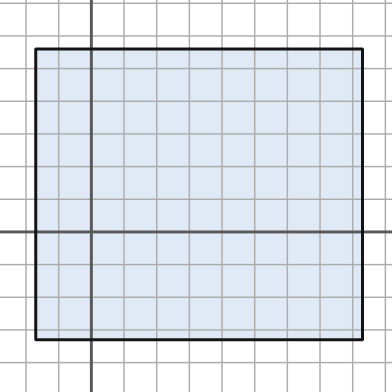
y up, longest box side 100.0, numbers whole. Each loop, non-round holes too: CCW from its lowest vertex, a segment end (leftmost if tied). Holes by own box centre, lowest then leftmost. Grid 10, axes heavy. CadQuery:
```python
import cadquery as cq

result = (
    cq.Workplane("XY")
    .moveTo(-17.0, -33.0)
    .lineTo(83.0, -33.0)
    .lineTo(83.0, 56.0)
    .lineTo(-17.0, 56.0)
    .close()
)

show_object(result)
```